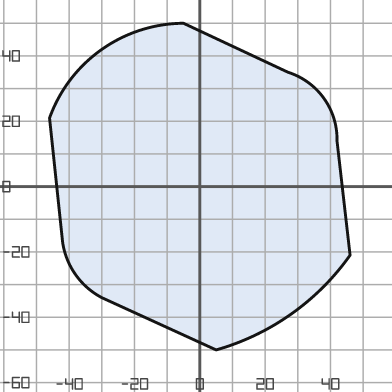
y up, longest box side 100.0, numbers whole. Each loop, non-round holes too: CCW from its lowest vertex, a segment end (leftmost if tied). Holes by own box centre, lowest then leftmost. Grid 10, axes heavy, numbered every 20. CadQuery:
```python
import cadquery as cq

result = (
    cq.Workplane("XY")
    .moveTo(5.0, -50.0)
    .threePointArc((28.0, -39.0), (46.0, -21.0))
    .lineTo(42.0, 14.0)
    .threePointArc((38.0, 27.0), (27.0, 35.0))
    .lineTo(-5.0, 50.0)
    .threePointArc((-30.0, 42.0), (-46.0, 21.0))
    .lineTo(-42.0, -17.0)
    .threePointArc((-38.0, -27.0), (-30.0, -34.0))
    .close()
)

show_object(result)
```